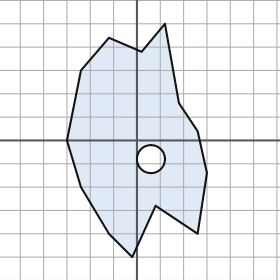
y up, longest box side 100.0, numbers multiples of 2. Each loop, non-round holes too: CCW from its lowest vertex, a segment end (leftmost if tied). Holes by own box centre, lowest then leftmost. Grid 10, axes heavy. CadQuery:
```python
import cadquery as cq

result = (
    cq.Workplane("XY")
    .moveTo(-2.0, -50.0)
    .lineTo(8.0, -28.0)
    .lineTo(26.0, -40.0)
    .lineTo(30.0, -14.0)
    .lineTo(26.0, 4.0)
    .lineTo(18.0, 16.0)
    .lineTo(12.0, 50.0)
    .lineTo(2.0, 38.0)
    .lineTo(-12.0, 44.0)
    .lineTo(-24.0, 30.0)
    .lineTo(-30.0, 0.0)
    .lineTo(-24.0, -20.0)
    .lineTo(-12.0, -40.0)
    .close()
    .moveTo(6.0, -8.0)
    .circle(6.0)
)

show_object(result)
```